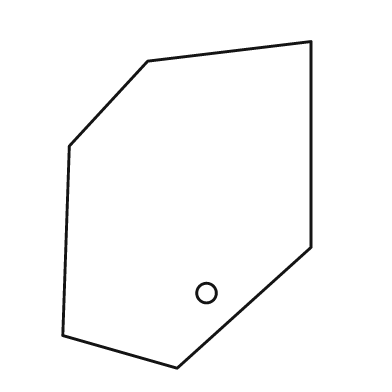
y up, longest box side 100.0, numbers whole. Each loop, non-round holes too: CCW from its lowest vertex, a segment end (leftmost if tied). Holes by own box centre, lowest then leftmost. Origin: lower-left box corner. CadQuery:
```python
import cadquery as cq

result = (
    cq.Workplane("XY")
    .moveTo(35.0, 0.0)
    .lineTo(76.0, 37.0)
    .lineTo(76.0, 100.0)
    .lineTo(26.0, 94.0)
    .lineTo(2.0, 68.0)
    .lineTo(0.0, 10.0)
    .close()
    .moveTo(44.0, 23.0)
    .circle(3.0)
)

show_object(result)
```